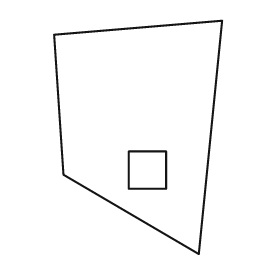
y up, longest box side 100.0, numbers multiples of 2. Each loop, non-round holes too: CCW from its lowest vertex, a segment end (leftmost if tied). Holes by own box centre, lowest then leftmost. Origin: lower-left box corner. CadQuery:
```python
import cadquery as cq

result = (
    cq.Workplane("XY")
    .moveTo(62.0, 0.0)
    .lineTo(72.0, 100.0)
    .lineTo(0.0, 94.0)
    .lineTo(4.0, 34.0)
    .close()
    .moveTo(32.0, 28.0)
    .lineTo(48.0, 28.0)
    .lineTo(48.0, 44.0)
    .lineTo(32.0, 44.0)
    .close()
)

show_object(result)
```